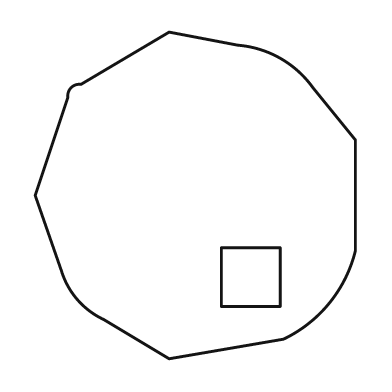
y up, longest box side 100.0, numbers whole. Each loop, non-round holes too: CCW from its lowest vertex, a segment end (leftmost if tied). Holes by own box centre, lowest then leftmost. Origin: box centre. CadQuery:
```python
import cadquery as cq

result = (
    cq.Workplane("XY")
    .moveTo(-8.0, -50.0)
    .lineTo(27.0, -44.0)
    .threePointArc((41.0, -33.0), (49.0, -17.0))
    .lineTo(49.0, 17.0)
    .lineTo(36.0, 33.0)
    .threePointArc((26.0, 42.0), (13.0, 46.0))
    .lineTo(-8.0, 50.0)
    .lineTo(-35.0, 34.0)
    .threePointArc((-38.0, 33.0), (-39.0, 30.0))
    .lineTo(-49.0, 0.0)
    .lineTo(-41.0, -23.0)
    .threePointArc((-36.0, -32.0), (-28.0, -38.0))
    .close()
    .moveTo(8.0, -34.0)
    .lineTo(26.0, -34.0)
    .lineTo(26.0, -16.0)
    .lineTo(8.0, -16.0)
    .close()
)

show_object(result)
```